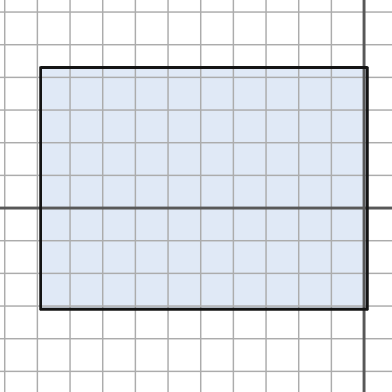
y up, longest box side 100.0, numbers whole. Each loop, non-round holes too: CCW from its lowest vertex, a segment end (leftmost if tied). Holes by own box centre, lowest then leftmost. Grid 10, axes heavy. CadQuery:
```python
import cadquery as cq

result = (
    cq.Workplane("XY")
    .moveTo(-99.0, -31.0)
    .lineTo(1.0, -31.0)
    .lineTo(1.0, 43.0)
    .lineTo(-99.0, 43.0)
    .close()
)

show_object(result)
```